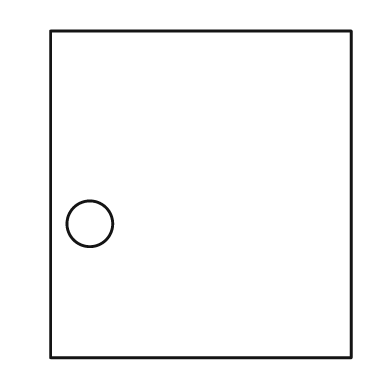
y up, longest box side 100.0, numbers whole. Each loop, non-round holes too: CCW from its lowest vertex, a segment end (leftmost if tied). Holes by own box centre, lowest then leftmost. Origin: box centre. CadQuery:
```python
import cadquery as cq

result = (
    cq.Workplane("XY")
    .moveTo(-46.0, -50.0)
    .lineTo(46.0, -50.0)
    .lineTo(46.0, 50.0)
    .lineTo(-46.0, 50.0)
    .close()
    .moveTo(-34.0, -9.0)
    .circle(7.0)
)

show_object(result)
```